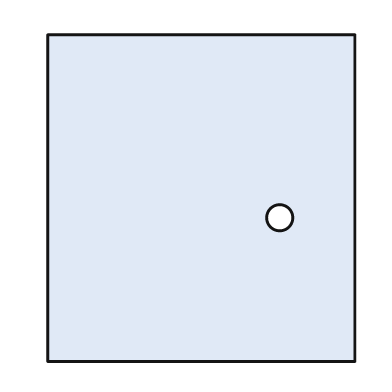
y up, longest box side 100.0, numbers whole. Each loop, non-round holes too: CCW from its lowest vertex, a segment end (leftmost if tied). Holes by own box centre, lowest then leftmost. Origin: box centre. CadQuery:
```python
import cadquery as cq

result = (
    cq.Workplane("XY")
    .moveTo(-47.0, -50.0)
    .lineTo(47.0, -50.0)
    .lineTo(47.0, 50.0)
    .lineTo(-47.0, 50.0)
    .close()
    .moveTo(24.0, -6.0)
    .circle(4.0)
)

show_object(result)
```